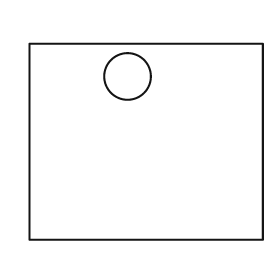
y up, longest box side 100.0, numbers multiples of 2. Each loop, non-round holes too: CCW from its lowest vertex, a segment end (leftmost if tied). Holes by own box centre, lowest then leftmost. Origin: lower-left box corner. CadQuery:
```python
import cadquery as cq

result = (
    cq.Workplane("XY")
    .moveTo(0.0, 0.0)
    .lineTo(100.0, 0.0)
    .lineTo(100.0, 84.0)
    .lineTo(0.0, 84.0)
    .close()
    .moveTo(42.0, 70.0)
    .circle(10.0)
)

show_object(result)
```